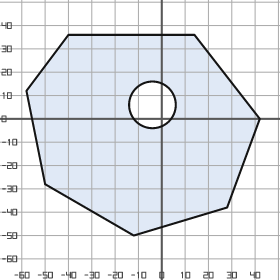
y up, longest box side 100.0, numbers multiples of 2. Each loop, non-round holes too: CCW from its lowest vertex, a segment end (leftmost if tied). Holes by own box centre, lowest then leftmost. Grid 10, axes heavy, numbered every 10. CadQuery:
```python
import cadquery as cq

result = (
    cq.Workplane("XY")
    .moveTo(-12.0, -50.0)
    .lineTo(28.0, -38.0)
    .lineTo(42.0, 0.0)
    .lineTo(14.0, 36.0)
    .lineTo(-40.0, 36.0)
    .lineTo(-58.0, 12.0)
    .lineTo(-50.0, -28.0)
    .close()
    .moveTo(-4.0, 6.0)
    .circle(10.0)
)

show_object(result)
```